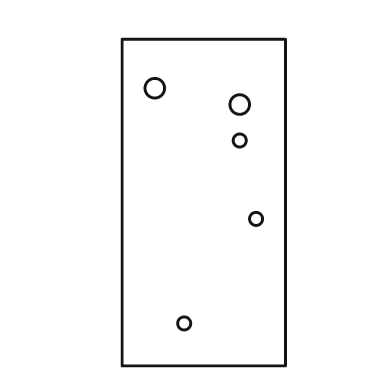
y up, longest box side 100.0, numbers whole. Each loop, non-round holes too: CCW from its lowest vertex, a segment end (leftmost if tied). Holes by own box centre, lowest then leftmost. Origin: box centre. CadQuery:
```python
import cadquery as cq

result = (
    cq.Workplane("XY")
    .moveTo(-25.0, -50.0)
    .lineTo(25.0, -50.0)
    .lineTo(25.0, 50.0)
    .lineTo(-25.0, 50.0)
    .close()
    .moveTo(-6.0, -37.0)
    .circle(2.0)
    .moveTo(16.0, -5.0)
    .circle(2.0)
    .moveTo(11.0, 19.0)
    .circle(2.0)
    .moveTo(11.0, 30.0)
    .circle(3.0)
    .moveTo(-15.0, 35.0)
    .circle(3.0)
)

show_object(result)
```